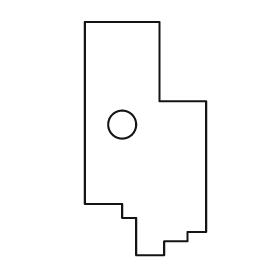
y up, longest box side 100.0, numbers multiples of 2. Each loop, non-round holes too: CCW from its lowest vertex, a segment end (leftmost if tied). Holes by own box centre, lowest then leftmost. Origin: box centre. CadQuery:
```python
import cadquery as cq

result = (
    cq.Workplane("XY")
    .moveTo(-4.0, -50.0)
    .lineTo(8.0, -50.0)
    .lineTo(8.0, -44.0)
    .lineTo(18.0, -44.0)
    .lineTo(18.0, -40.0)
    .lineTo(26.0, -40.0)
    .lineTo(26.0, 16.0)
    .lineTo(6.0, 16.0)
    .lineTo(6.0, 50.0)
    .lineTo(-26.0, 50.0)
    .lineTo(-26.0, -28.0)
    .lineTo(-10.0, -28.0)
    .lineTo(-10.0, -34.0)
    .lineTo(-4.0, -34.0)
    .close()
    .moveTo(-10.0, 6.0)
    .circle(6.0)
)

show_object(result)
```